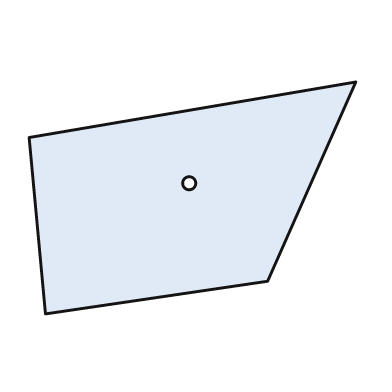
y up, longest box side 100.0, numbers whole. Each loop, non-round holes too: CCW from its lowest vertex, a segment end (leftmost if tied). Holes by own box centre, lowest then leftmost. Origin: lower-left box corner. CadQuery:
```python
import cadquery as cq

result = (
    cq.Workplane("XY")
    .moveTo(5.0, 0.0)
    .lineTo(73.0, 10.0)
    .lineTo(100.0, 71.0)
    .lineTo(0.0, 54.0)
    .close()
    .moveTo(49.0, 40.0)
    .circle(2.0)
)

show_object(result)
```